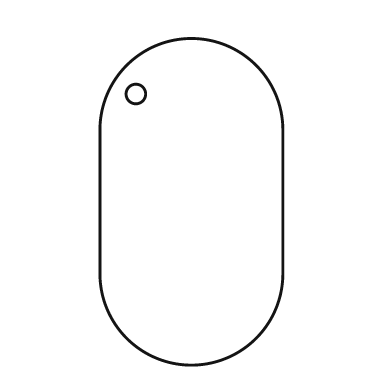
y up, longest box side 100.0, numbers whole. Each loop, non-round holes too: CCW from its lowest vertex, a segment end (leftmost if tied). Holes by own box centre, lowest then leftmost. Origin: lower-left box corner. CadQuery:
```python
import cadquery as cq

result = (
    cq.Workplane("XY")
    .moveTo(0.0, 28.0)
    .threePointArc((28.0, 0.0), (56.0, 28.0))
    .lineTo(56.0, 72.0)
    .threePointArc((28.0, 100.0), (0.0, 72.0))
    .close()
    .moveTo(11.0, 83.0)
    .circle(3.0)
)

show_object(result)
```